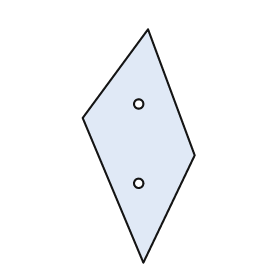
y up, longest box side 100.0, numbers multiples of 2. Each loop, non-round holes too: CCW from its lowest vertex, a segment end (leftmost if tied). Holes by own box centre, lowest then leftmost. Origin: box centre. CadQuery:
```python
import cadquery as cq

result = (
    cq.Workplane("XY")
    .moveTo(2.0, -50.0)
    .lineTo(24.0, -4.0)
    .lineTo(4.0, 50.0)
    .lineTo(-24.0, 12.0)
    .close()
    .moveTo(0.0, -16.0)
    .circle(2.0)
    .moveTo(0.0, 18.0)
    .circle(2.0)
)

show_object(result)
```